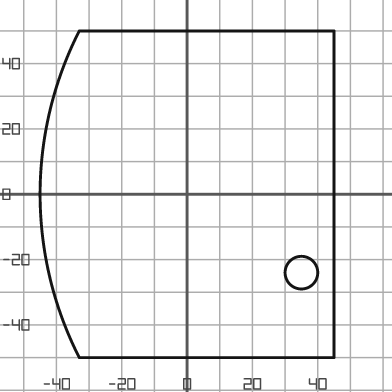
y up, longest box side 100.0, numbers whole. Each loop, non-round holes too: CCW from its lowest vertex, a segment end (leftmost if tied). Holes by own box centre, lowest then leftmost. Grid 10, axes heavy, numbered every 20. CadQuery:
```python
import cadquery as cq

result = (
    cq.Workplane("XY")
    .moveTo(-33.0, -50.0)
    .lineTo(45.0, -50.0)
    .lineTo(45.0, 50.0)
    .lineTo(-33.0, 50.0)
    .threePointArc((-45.0, 0.0), (-33.0, -50.0))
    .close()
    .moveTo(35.0, -24.0)
    .circle(5.0)
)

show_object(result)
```